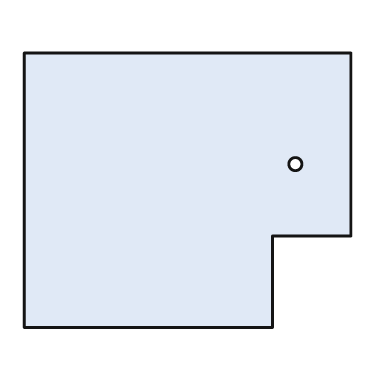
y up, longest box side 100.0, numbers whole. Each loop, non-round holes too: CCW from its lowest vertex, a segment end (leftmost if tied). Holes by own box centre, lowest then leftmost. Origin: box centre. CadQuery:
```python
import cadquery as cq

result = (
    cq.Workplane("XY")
    .moveTo(-50.0, -42.0)
    .lineTo(26.0, -42.0)
    .lineTo(26.0, -14.0)
    .lineTo(50.0, -14.0)
    .lineTo(50.0, 42.0)
    .lineTo(-50.0, 42.0)
    .close()
    .moveTo(33.0, 8.0)
    .circle(2.0)
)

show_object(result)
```